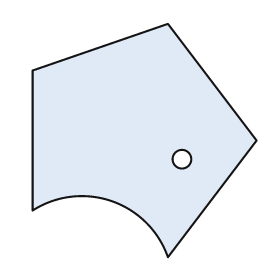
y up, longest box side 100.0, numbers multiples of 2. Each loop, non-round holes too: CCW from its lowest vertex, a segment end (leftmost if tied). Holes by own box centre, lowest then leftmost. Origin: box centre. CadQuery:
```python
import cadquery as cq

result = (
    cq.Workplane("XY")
    .moveTo(10.0, -50.0)
    .lineTo(48.0, 0.0)
    .lineTo(10.0, 50.0)
    .lineTo(-48.0, 30.0)
    .lineTo(-48.0, -30.0)
    .threePointArc((-14.0, -26.0), (10.0, -50.0))
    .close()
    .moveTo(16.0, -8.0)
    .circle(4.0)
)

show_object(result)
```